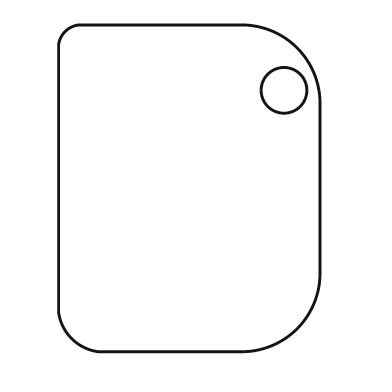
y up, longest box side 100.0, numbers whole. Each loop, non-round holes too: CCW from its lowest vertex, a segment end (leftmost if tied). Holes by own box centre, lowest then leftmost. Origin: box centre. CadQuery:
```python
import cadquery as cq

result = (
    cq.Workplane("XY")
    .moveTo(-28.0, -50.0)
    .lineTo(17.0, -50.0)
    .threePointArc((33.0, -43.0), (40.0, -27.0))
    .lineTo(40.0, 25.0)
    .threePointArc((33.0, 43.0), (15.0, 50.0))
    .lineTo(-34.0, 50.0)
    .threePointArc((-38.0, 48.0), (-40.0, 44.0))
    .lineTo(-40.0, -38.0)
    .threePointArc((-36.0, -46.0), (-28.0, -50.0))
    .close()
    .moveTo(29.0, 30.0)
    .circle(7.0)
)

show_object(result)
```